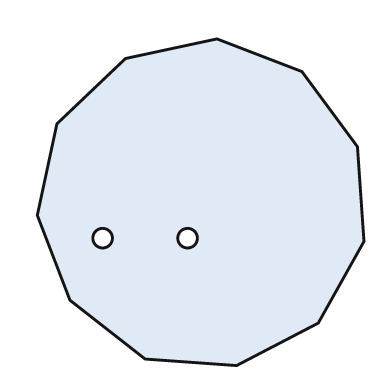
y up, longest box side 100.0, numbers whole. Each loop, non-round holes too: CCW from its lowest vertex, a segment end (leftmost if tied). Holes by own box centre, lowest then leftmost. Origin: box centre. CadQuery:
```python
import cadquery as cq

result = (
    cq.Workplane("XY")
    .moveTo(11.0, -50.0)
    .lineTo(36.0, -37.0)
    .lineTo(50.0, -12.0)
    .lineTo(48.0, 17.0)
    .lineTo(31.0, 40.0)
    .lineTo(5.0, 50.0)
    .lineTo(-23.0, 44.0)
    .lineTo(-44.0, 24.0)
    .lineTo(-50.0, -4.0)
    .lineTo(-40.0, -30.0)
    .lineTo(-17.0, -48.0)
    .close()
    .moveTo(-30.0, -11.0)
    .circle(3.0)
    .moveTo(-4.0, -11.0)
    .circle(3.0)
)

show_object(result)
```